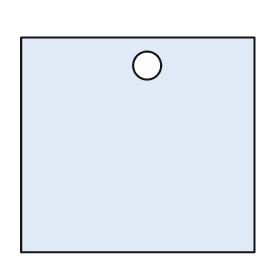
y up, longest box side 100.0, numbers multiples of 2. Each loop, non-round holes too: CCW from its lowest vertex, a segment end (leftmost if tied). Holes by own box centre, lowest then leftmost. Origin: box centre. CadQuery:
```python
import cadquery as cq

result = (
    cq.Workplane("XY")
    .moveTo(-50.0, -46.0)
    .lineTo(50.0, -46.0)
    .lineTo(50.0, 46.0)
    .lineTo(-50.0, 46.0)
    .close()
    .moveTo(4.0, 34.0)
    .circle(6.0)
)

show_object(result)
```